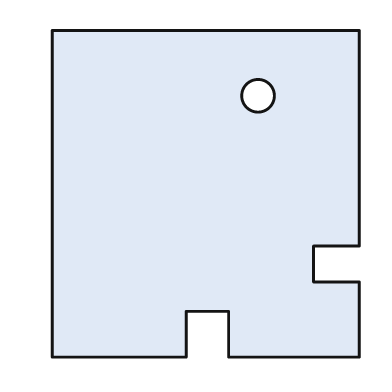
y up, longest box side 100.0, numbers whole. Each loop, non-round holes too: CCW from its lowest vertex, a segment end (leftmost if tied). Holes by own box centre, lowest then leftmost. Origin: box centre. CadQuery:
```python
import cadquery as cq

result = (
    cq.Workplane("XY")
    .moveTo(-47.0, -50.0)
    .lineTo(-6.0, -50.0)
    .lineTo(-6.0, -36.0)
    .lineTo(7.0, -36.0)
    .lineTo(7.0, -50.0)
    .lineTo(47.0, -50.0)
    .lineTo(47.0, -27.0)
    .lineTo(33.0, -27.0)
    .lineTo(33.0, -16.0)
    .lineTo(47.0, -16.0)
    .lineTo(47.0, 50.0)
    .lineTo(-47.0, 50.0)
    .close()
    .moveTo(16.0, 30.0)
    .circle(5.0)
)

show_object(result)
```